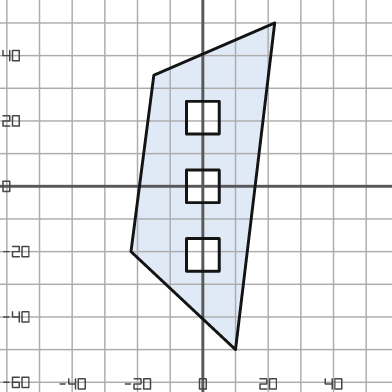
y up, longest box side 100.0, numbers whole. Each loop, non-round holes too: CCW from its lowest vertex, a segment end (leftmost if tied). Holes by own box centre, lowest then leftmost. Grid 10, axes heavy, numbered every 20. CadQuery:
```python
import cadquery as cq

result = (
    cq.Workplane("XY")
    .moveTo(10.0, -50.0)
    .lineTo(22.0, 50.0)
    .lineTo(-15.0, 34.0)
    .lineTo(-22.0, -20.0)
    .close()
    .moveTo(-5.0, -26.0)
    .lineTo(5.0, -26.0)
    .lineTo(5.0, -16.0)
    .lineTo(-5.0, -16.0)
    .close()
    .moveTo(-5.0, -5.0)
    .lineTo(5.0, -5.0)
    .lineTo(5.0, 5.0)
    .lineTo(-5.0, 5.0)
    .close()
    .moveTo(-5.0, 16.0)
    .lineTo(5.0, 16.0)
    .lineTo(5.0, 26.0)
    .lineTo(-5.0, 26.0)
    .close()
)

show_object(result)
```